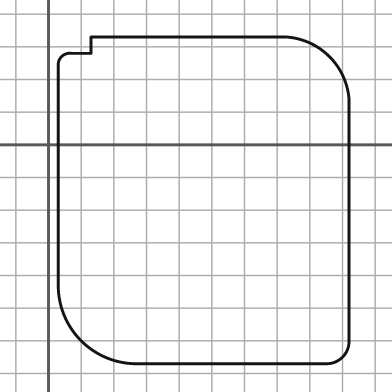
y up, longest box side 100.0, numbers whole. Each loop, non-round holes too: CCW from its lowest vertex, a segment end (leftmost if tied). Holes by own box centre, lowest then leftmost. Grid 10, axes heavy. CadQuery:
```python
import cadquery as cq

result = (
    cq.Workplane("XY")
    .moveTo(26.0, -67.0)
    .lineTo(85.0, -67.0)
    .threePointArc((90.0, -65.0), (92.0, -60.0))
    .lineTo(92.0, 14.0)
    .threePointArc((86.0, 27.0), (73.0, 33.0))
    .lineTo(13.0, 33.0)
    .lineTo(13.0, 28.0)
    .lineTo(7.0, 28.0)
    .threePointArc((4.0, 27.0), (3.0, 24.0))
    .lineTo(3.0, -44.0)
    .threePointArc((10.0, -60.0), (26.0, -67.0))
    .close()
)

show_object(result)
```